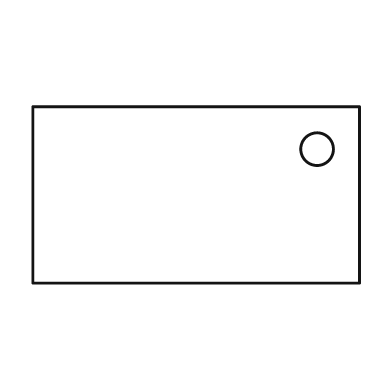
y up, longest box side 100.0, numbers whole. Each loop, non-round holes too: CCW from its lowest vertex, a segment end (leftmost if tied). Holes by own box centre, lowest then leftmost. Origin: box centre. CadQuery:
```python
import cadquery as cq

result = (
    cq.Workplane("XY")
    .moveTo(-50.0, -27.0)
    .lineTo(50.0, -27.0)
    .lineTo(50.0, 27.0)
    .lineTo(-50.0, 27.0)
    .close()
    .moveTo(37.0, 14.0)
    .circle(5.0)
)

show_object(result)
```